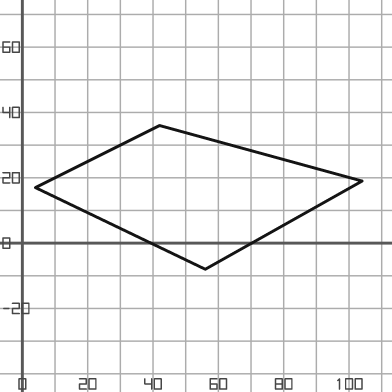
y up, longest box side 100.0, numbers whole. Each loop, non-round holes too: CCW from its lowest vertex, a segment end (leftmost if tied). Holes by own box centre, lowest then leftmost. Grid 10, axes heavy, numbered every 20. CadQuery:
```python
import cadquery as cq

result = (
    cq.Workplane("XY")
    .moveTo(56.0, -8.0)
    .lineTo(104.0, 19.0)
    .lineTo(42.0, 36.0)
    .lineTo(4.0, 17.0)
    .close()
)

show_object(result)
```